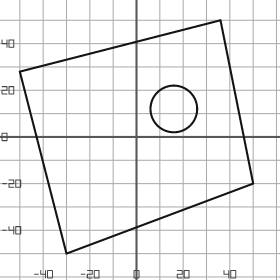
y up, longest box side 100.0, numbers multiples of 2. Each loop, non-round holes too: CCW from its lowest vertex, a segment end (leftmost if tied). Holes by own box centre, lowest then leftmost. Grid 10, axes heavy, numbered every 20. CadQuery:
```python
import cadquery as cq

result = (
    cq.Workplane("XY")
    .moveTo(-30.0, -50.0)
    .lineTo(50.0, -20.0)
    .lineTo(36.0, 50.0)
    .lineTo(-50.0, 28.0)
    .close()
    .moveTo(16.0, 12.0)
    .circle(10.0)
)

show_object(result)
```